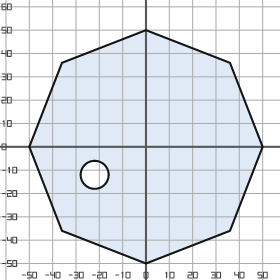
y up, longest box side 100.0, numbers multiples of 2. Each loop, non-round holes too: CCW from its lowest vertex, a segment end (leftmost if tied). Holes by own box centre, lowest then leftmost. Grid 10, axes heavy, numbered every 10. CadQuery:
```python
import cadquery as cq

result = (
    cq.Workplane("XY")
    .moveTo(0.0, -50.0)
    .lineTo(36.0, -36.0)
    .lineTo(50.0, 0.0)
    .lineTo(36.0, 36.0)
    .lineTo(0.0, 50.0)
    .lineTo(-36.0, 36.0)
    .lineTo(-50.0, 0.0)
    .lineTo(-36.0, -36.0)
    .close()
    .moveTo(-22.0, -12.0)
    .circle(6.0)
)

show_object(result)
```